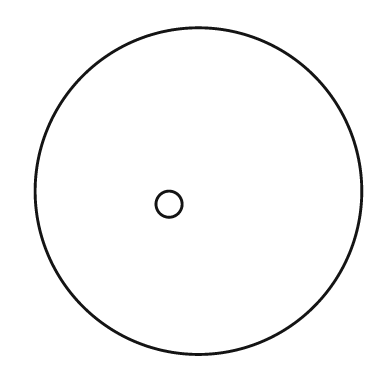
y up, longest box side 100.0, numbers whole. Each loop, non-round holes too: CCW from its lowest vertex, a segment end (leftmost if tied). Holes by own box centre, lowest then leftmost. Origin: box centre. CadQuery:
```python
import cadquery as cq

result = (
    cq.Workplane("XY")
    .moveTo(0.0, 0.0)
    .circle(50.0)
    .moveTo(-9.0, -4.0)
    .circle(4.0)
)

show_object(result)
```